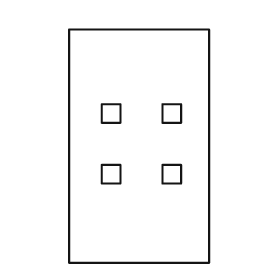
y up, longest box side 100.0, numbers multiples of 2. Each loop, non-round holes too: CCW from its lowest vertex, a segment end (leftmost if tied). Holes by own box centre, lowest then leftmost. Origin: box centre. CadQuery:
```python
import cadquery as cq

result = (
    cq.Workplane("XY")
    .moveTo(-30.0, -50.0)
    .lineTo(30.0, -50.0)
    .lineTo(30.0, 50.0)
    .lineTo(-30.0, 50.0)
    .close()
    .moveTo(-16.0, -16.0)
    .lineTo(-8.0, -16.0)
    .lineTo(-8.0, -8.0)
    .lineTo(-16.0, -8.0)
    .close()
    .moveTo(10.0, -16.0)
    .lineTo(18.0, -16.0)
    .lineTo(18.0, -8.0)
    .lineTo(10.0, -8.0)
    .close()
    .moveTo(-16.0, 10.0)
    .lineTo(-8.0, 10.0)
    .lineTo(-8.0, 18.0)
    .lineTo(-16.0, 18.0)
    .close()
    .moveTo(10.0, 10.0)
    .lineTo(18.0, 10.0)
    .lineTo(18.0, 18.0)
    .lineTo(10.0, 18.0)
    .close()
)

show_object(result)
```